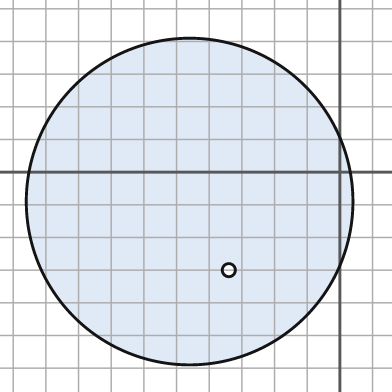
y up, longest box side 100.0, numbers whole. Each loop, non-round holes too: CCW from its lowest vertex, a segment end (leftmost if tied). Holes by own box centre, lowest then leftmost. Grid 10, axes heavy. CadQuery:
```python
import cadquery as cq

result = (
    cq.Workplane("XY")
    .moveTo(-46.0, -9.0)
    .circle(50.0)
    .moveTo(-34.0, -30.0)
    .circle(2.0)
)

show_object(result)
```